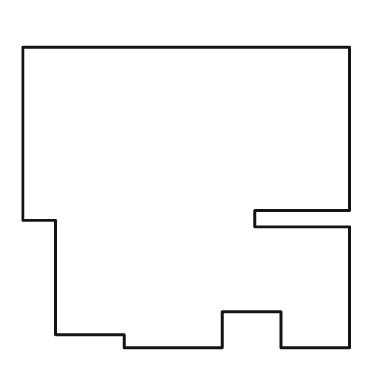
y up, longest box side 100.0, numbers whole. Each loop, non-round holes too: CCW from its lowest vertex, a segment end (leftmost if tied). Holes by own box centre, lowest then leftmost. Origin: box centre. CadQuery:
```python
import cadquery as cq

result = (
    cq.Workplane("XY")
    .moveTo(-19.0, -46.0)
    .lineTo(11.0, -46.0)
    .lineTo(11.0, -35.0)
    .lineTo(29.0, -35.0)
    .lineTo(29.0, -46.0)
    .lineTo(50.0, -46.0)
    .lineTo(50.0, -9.0)
    .lineTo(21.0, -9.0)
    .lineTo(21.0, -4.0)
    .lineTo(50.0, -4.0)
    .lineTo(50.0, 46.0)
    .lineTo(-50.0, 46.0)
    .lineTo(-50.0, -7.0)
    .lineTo(-40.0, -7.0)
    .lineTo(-40.0, -42.0)
    .lineTo(-19.0, -42.0)
    .close()
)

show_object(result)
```